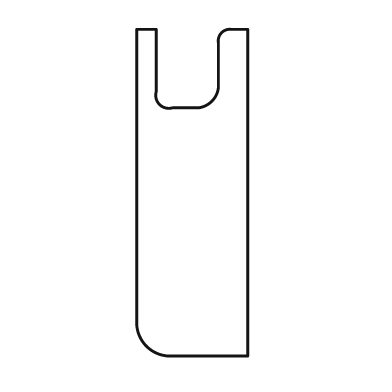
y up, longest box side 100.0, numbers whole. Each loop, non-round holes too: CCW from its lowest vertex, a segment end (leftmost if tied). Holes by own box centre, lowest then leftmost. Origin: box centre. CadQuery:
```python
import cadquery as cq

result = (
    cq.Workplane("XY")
    .moveTo(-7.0, -50.0)
    .lineTo(17.0, -50.0)
    .lineTo(17.0, 50.0)
    .lineTo(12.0, 50.0)
    .threePointArc((9.0, 49.0), (8.0, 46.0))
    .lineTo(8.0, 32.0)
    .threePointArc((6.0, 28.0), (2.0, 26.0))
    .lineTo(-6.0, 26.0)
    .threePointArc((-10.0, 27.0), (-11.0, 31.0))
    .lineTo(-11.0, 50.0)
    .lineTo(-17.0, 50.0)
    .lineTo(-17.0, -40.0)
    .threePointArc((-14.0, -47.0), (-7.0, -50.0))
    .close()
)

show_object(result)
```